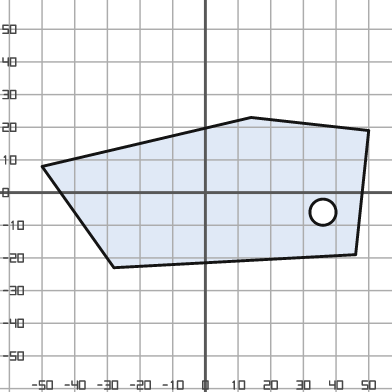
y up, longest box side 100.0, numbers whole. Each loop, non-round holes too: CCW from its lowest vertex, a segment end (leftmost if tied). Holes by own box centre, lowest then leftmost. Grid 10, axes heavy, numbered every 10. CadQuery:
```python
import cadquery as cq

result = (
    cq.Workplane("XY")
    .moveTo(-28.0, -23.0)
    .lineTo(46.0, -19.0)
    .lineTo(50.0, 19.0)
    .lineTo(14.0, 23.0)
    .lineTo(-50.0, 8.0)
    .close()
    .moveTo(36.0, -6.0)
    .circle(4.0)
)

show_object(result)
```